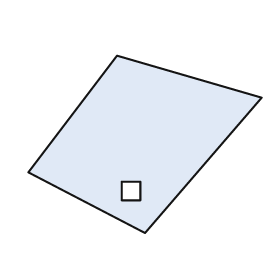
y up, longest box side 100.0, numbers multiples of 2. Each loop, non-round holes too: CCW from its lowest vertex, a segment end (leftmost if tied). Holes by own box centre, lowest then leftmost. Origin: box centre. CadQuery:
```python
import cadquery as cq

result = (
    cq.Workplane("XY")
    .moveTo(0.0, -38.0)
    .lineTo(50.0, 20.0)
    .lineTo(-12.0, 38.0)
    .lineTo(-50.0, -12.0)
    .close()
    .moveTo(-10.0, -24.0)
    .lineTo(-2.0, -24.0)
    .lineTo(-2.0, -16.0)
    .lineTo(-10.0, -16.0)
    .close()
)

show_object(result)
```